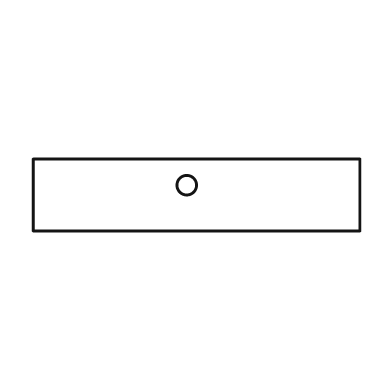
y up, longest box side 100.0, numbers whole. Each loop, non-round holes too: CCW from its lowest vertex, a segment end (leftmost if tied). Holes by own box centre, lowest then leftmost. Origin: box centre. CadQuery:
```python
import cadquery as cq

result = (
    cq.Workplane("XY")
    .moveTo(-50.0, -11.0)
    .lineTo(50.0, -11.0)
    .lineTo(50.0, 11.0)
    .lineTo(-50.0, 11.0)
    .close()
    .moveTo(-3.0, 3.0)
    .circle(3.0)
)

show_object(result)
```